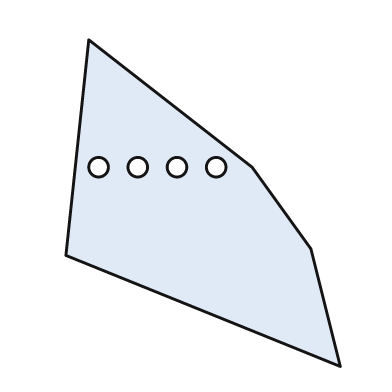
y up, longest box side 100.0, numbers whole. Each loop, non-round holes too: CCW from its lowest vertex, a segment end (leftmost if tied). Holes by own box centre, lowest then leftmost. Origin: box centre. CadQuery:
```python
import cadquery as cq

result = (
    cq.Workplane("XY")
    .moveTo(42.0, -50.0)
    .lineTo(33.0, -14.0)
    .lineTo(15.0, 11.0)
    .lineTo(-35.0, 50.0)
    .lineTo(-42.0, -16.0)
    .close()
    .moveTo(-32.0, 11.0)
    .circle(3.0)
    .moveTo(-20.0, 11.0)
    .circle(3.0)
    .moveTo(-8.0, 11.0)
    .circle(3.0)
    .moveTo(4.0, 11.0)
    .circle(3.0)
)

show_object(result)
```